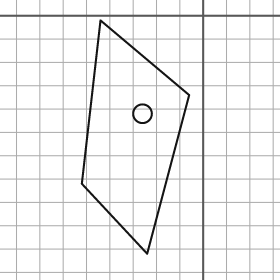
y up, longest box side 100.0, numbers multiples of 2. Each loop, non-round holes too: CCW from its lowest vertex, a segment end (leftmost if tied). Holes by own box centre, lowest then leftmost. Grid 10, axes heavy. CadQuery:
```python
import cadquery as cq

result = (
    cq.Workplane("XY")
    .moveTo(-24.0, -102.0)
    .lineTo(-6.0, -34.0)
    .lineTo(-44.0, -2.0)
    .lineTo(-52.0, -72.0)
    .close()
    .moveTo(-26.0, -42.0)
    .circle(4.0)
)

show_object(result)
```